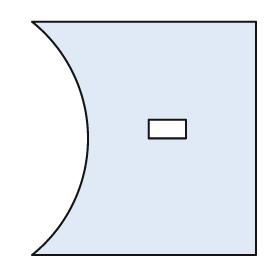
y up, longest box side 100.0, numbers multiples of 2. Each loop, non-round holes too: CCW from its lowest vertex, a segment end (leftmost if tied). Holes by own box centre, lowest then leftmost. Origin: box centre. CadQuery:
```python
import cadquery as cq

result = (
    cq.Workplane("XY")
    .moveTo(-48.0, -50.0)
    .lineTo(48.0, -50.0)
    .lineTo(48.0, 50.0)
    .lineTo(-48.0, 50.0)
    .threePointArc((-24.0, 0.0), (-48.0, -50.0))
    .close()
    .moveTo(2.0, 0.0)
    .lineTo(18.0, 0.0)
    .lineTo(18.0, 8.0)
    .lineTo(2.0, 8.0)
    .close()
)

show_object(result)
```